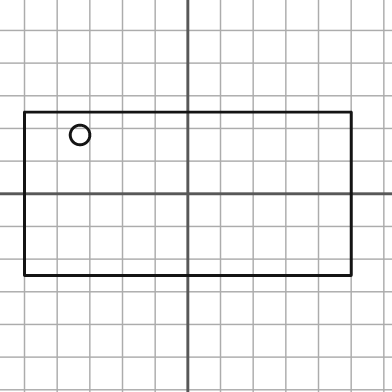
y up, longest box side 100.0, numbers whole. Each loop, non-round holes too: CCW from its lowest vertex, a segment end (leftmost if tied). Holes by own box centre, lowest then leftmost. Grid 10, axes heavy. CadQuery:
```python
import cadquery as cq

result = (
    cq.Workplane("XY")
    .moveTo(-50.0, -25.0)
    .lineTo(50.0, -25.0)
    .lineTo(50.0, 25.0)
    .lineTo(-50.0, 25.0)
    .close()
    .moveTo(-33.0, 18.0)
    .circle(3.0)
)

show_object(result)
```